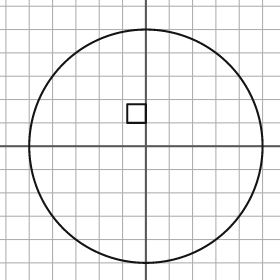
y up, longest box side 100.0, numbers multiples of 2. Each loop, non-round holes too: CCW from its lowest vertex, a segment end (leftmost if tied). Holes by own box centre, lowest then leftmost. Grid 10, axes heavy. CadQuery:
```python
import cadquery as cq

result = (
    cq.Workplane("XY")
    .moveTo(0.0, 0.0)
    .circle(50.0)
    .moveTo(-8.0, 10.0)
    .lineTo(0.0, 10.0)
    .lineTo(0.0, 18.0)
    .lineTo(-8.0, 18.0)
    .close()
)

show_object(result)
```